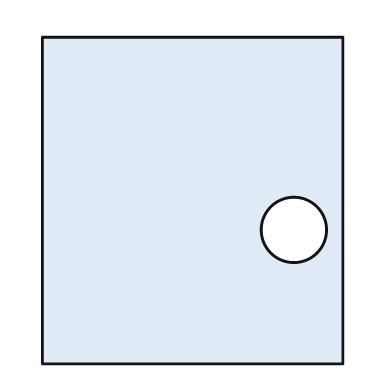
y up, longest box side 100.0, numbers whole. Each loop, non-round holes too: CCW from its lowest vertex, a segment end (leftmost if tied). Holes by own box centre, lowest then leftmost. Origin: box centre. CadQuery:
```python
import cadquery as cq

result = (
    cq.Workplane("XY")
    .moveTo(-46.0, -50.0)
    .lineTo(46.0, -50.0)
    .lineTo(46.0, 50.0)
    .lineTo(-46.0, 50.0)
    .close()
    .moveTo(31.0, -9.0)
    .circle(10.0)
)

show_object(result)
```